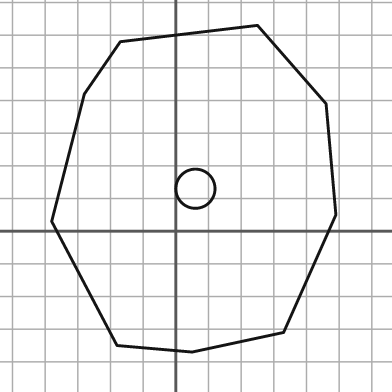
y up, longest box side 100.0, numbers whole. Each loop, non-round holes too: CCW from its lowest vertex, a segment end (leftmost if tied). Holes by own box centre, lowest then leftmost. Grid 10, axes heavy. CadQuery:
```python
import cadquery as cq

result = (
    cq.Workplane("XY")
    .moveTo(5.0, -37.0)
    .lineTo(33.0, -31.0)
    .lineTo(49.0, 5.0)
    .lineTo(46.0, 39.0)
    .lineTo(25.0, 63.0)
    .lineTo(-17.0, 58.0)
    .lineTo(-28.0, 42.0)
    .lineTo(-38.0, 3.0)
    .lineTo(-18.0, -35.0)
    .close()
    .moveTo(6.0, 13.0)
    .circle(6.0)
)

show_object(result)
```